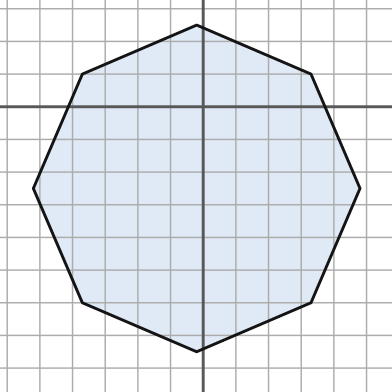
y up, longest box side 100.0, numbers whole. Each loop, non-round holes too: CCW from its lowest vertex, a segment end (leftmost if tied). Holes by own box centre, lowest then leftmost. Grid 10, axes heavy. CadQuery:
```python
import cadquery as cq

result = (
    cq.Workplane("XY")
    .moveTo(-2.0, -75.0)
    .lineTo(33.0, -60.0)
    .lineTo(48.0, -25.0)
    .lineTo(33.0, 10.0)
    .lineTo(-2.0, 25.0)
    .lineTo(-37.0, 10.0)
    .lineTo(-52.0, -25.0)
    .lineTo(-37.0, -60.0)
    .close()
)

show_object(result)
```